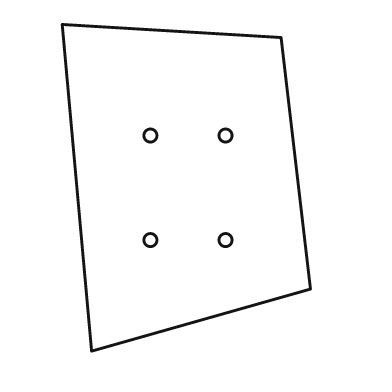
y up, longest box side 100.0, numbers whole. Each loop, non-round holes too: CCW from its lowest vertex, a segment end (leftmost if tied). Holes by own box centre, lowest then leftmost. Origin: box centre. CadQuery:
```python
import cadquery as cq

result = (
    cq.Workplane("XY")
    .moveTo(-29.0, -50.0)
    .lineTo(38.0, -31.0)
    .lineTo(29.0, 46.0)
    .lineTo(-38.0, 50.0)
    .close()
    .moveTo(-11.0, -16.0)
    .circle(2.0)
    .moveTo(12.0, -16.0)
    .circle(2.0)
    .moveTo(-11.0, 16.0)
    .circle(2.0)
    .moveTo(12.0, 16.0)
    .circle(2.0)
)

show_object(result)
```